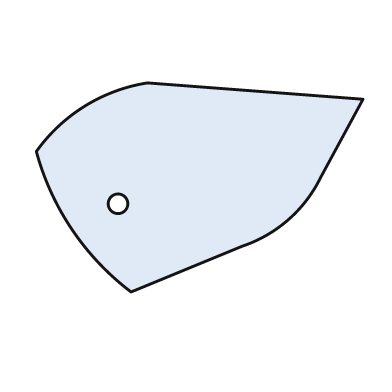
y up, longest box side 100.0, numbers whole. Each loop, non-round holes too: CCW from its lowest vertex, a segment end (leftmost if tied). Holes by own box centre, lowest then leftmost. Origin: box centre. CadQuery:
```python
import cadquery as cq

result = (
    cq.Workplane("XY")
    .moveTo(-21.0, -32.0)
    .lineTo(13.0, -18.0)
    .threePointArc((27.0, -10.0), (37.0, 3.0))
    .lineTo(50.0, 27.0)
    .lineTo(-16.0, 32.0)
    .threePointArc((-35.0, 25.0), (-50.0, 11.0))
    .threePointArc((-39.0, -13.0), (-21.0, -32.0))
    .close()
    .moveTo(-25.0, -5.0)
    .circle(3.0)
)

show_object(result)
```